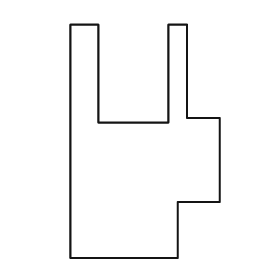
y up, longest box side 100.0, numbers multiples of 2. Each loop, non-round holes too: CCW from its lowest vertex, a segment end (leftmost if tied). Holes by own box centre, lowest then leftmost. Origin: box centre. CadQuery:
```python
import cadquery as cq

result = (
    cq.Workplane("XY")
    .moveTo(-32.0, -50.0)
    .lineTo(14.0, -50.0)
    .lineTo(14.0, -26.0)
    .lineTo(32.0, -26.0)
    .lineTo(32.0, 10.0)
    .lineTo(18.0, 10.0)
    .lineTo(18.0, 50.0)
    .lineTo(10.0, 50.0)
    .lineTo(10.0, 8.0)
    .lineTo(-20.0, 8.0)
    .lineTo(-20.0, 50.0)
    .lineTo(-32.0, 50.0)
    .close()
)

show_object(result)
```